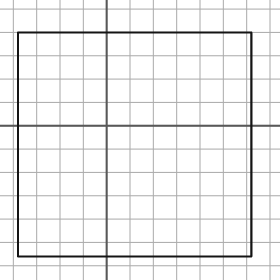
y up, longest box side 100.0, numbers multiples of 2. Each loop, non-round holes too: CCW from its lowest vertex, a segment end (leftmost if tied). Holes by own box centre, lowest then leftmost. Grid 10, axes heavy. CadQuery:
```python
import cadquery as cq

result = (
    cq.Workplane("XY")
    .moveTo(-38.0, -56.0)
    .lineTo(62.0, -56.0)
    .lineTo(62.0, 40.0)
    .lineTo(-38.0, 40.0)
    .close()
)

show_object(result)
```